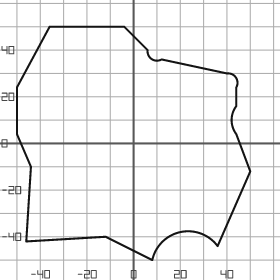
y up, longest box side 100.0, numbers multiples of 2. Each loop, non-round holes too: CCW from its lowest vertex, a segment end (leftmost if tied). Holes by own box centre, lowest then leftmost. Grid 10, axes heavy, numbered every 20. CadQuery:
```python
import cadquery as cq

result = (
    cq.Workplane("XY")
    .moveTo(8.0, -50.0)
    .threePointArc((20.0, -38.0), (36.0, -44.0))
    .lineTo(50.0, -12.0)
    .lineTo(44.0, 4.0)
    .threePointArc((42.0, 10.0), (44.0, 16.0))
    .lineTo(44.0, 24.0)
    .threePointArc((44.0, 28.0), (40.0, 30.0))
    .lineTo(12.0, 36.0)
    .threePointArc((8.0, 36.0), (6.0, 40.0))
    .lineTo(-4.0, 50.0)
    .lineTo(-36.0, 50.0)
    .lineTo(-50.0, 24.0)
    .lineTo(-50.0, 4.0)
    .lineTo(-44.0, -10.0)
    .lineTo(-46.0, -42.0)
    .lineTo(-12.0, -40.0)
    .close()
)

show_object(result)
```